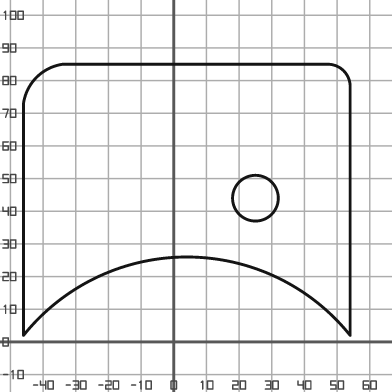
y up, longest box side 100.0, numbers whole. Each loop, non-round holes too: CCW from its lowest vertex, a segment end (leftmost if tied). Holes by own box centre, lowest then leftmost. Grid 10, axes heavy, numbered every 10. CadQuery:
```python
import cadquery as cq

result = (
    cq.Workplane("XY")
    .moveTo(-46.0, 2.0)
    .threePointArc((4.0, 26.0), (54.0, 2.0))
    .lineTo(54.0, 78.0)
    .threePointArc((52.0, 83.0), (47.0, 85.0))
    .lineTo(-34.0, 85.0)
    .threePointArc((-42.0, 81.0), (-46.0, 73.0))
    .close()
    .moveTo(25.0, 44.0)
    .circle(7.0)
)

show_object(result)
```